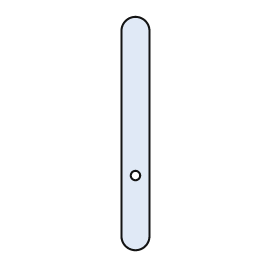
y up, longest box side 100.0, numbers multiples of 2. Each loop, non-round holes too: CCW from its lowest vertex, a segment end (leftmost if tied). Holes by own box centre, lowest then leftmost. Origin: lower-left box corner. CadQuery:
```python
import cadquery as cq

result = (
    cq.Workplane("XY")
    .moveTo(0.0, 6.0)
    .threePointArc((6.0, 0.0), (12.0, 6.0))
    .lineTo(12.0, 94.0)
    .threePointArc((6.0, 100.0), (0.0, 94.0))
    .close()
    .moveTo(6.0, 32.0)
    .circle(2.0)
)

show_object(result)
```